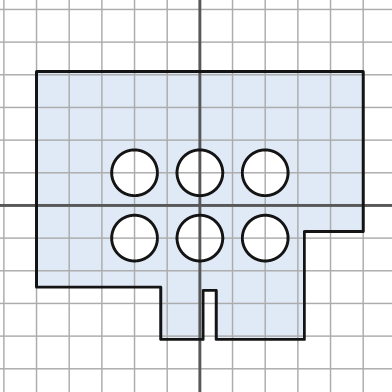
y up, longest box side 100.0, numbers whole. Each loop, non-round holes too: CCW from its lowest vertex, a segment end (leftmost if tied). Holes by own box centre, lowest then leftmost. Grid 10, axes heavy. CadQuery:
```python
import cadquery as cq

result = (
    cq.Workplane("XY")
    .moveTo(-12.0, -41.0)
    .lineTo(1.0, -41.0)
    .lineTo(1.0, -26.0)
    .lineTo(5.0, -26.0)
    .lineTo(5.0, -41.0)
    .lineTo(32.0, -41.0)
    .lineTo(32.0, -8.0)
    .lineTo(50.0, -8.0)
    .lineTo(50.0, 41.0)
    .lineTo(-50.0, 41.0)
    .lineTo(-50.0, -25.0)
    .lineTo(-12.0, -25.0)
    .close()
    .moveTo(-20.0, -10.0)
    .circle(7.0)
    .moveTo(0.0, -10.0)
    .circle(7.0)
    .moveTo(20.0, -10.0)
    .circle(7.0)
    .moveTo(-20.0, 10.0)
    .circle(7.0)
    .moveTo(0.0, 10.0)
    .circle(7.0)
    .moveTo(20.0, 10.0)
    .circle(7.0)
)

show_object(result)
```